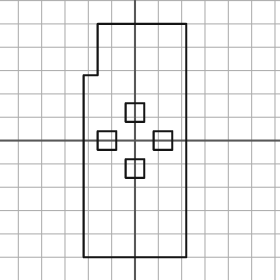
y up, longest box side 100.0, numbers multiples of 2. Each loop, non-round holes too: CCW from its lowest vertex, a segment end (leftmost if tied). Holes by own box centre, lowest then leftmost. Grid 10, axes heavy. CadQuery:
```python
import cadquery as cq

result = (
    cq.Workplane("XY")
    .moveTo(-22.0, -50.0)
    .lineTo(22.0, -50.0)
    .lineTo(22.0, 50.0)
    .lineTo(-16.0, 50.0)
    .lineTo(-16.0, 28.0)
    .lineTo(-22.0, 28.0)
    .close()
    .moveTo(-4.0, -16.0)
    .lineTo(4.0, -16.0)
    .lineTo(4.0, -8.0)
    .lineTo(-4.0, -8.0)
    .close()
    .moveTo(-16.0, -4.0)
    .lineTo(-8.0, -4.0)
    .lineTo(-8.0, 4.0)
    .lineTo(-16.0, 4.0)
    .close()
    .moveTo(8.0, -4.0)
    .lineTo(16.0, -4.0)
    .lineTo(16.0, 4.0)
    .lineTo(8.0, 4.0)
    .close()
    .moveTo(-4.0, 8.0)
    .lineTo(4.0, 8.0)
    .lineTo(4.0, 16.0)
    .lineTo(-4.0, 16.0)
    .close()
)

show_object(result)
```